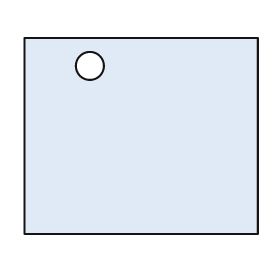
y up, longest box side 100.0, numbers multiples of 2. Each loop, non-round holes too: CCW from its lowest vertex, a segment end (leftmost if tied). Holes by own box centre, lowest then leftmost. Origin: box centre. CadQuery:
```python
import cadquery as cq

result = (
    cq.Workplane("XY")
    .moveTo(-50.0, -42.0)
    .lineTo(50.0, -42.0)
    .lineTo(50.0, 42.0)
    .lineTo(-50.0, 42.0)
    .close()
    .moveTo(-22.0, 30.0)
    .circle(6.0)
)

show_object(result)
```